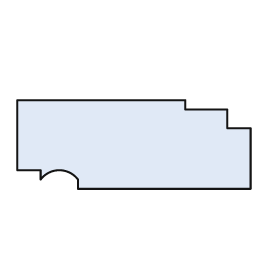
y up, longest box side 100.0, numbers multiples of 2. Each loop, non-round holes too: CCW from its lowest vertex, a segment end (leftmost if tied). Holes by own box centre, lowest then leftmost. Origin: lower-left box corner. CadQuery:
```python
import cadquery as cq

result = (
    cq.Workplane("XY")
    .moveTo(26.0, 0.0)
    .lineTo(100.0, 0.0)
    .lineTo(100.0, 26.0)
    .lineTo(90.0, 26.0)
    .lineTo(90.0, 34.0)
    .lineTo(72.0, 34.0)
    .lineTo(72.0, 38.0)
    .lineTo(0.0, 38.0)
    .lineTo(0.0, 8.0)
    .lineTo(10.0, 8.0)
    .lineTo(10.0, 4.0)
    .threePointArc((18.0, 8.0), (26.0, 4.0))
    .close()
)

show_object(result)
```